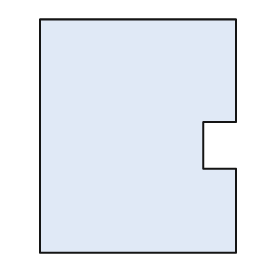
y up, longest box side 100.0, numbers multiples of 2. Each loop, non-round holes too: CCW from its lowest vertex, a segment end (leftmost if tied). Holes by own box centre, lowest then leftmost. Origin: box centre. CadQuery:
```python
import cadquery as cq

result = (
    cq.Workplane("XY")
    .moveTo(-42.0, -50.0)
    .lineTo(42.0, -50.0)
    .lineTo(42.0, -14.0)
    .lineTo(28.0, -14.0)
    .lineTo(28.0, 6.0)
    .lineTo(42.0, 6.0)
    .lineTo(42.0, 50.0)
    .lineTo(-42.0, 50.0)
    .close()
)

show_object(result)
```